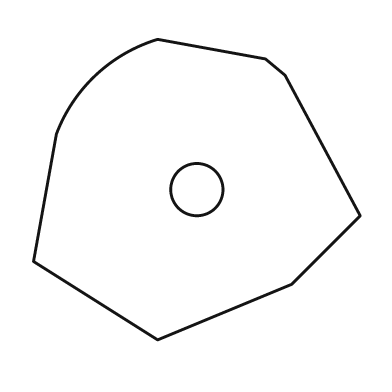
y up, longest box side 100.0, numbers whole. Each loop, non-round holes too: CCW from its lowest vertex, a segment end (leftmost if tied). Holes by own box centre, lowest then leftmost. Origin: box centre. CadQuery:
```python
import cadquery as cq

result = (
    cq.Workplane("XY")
    .moveTo(-12.0, -46.0)
    .lineTo(29.0, -29.0)
    .lineTo(50.0, -8.0)
    .lineTo(27.0, 35.0)
    .lineTo(21.0, 40.0)
    .lineTo(-12.0, 46.0)
    .threePointArc((-31.0, 35.0), (-43.0, 17.0))
    .lineTo(-50.0, -22.0)
    .close()
    .moveTo(0.0, 0.0)
    .circle(8.0)
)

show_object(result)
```